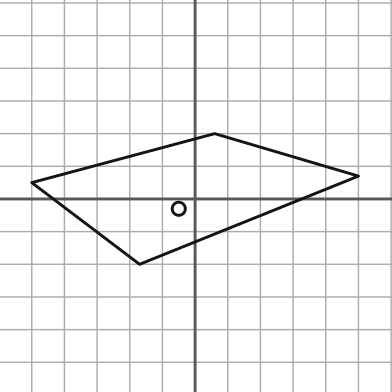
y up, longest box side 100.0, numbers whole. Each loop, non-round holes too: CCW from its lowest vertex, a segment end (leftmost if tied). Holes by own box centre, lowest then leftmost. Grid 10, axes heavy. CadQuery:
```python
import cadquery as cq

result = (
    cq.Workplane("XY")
    .moveTo(-17.0, -20.0)
    .lineTo(50.0, 7.0)
    .lineTo(6.0, 20.0)
    .lineTo(-50.0, 5.0)
    .close()
    .moveTo(-5.0, -3.0)
    .circle(2.0)
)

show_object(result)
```